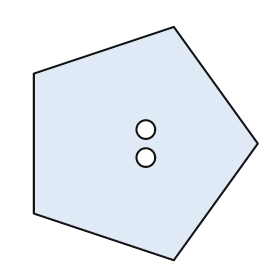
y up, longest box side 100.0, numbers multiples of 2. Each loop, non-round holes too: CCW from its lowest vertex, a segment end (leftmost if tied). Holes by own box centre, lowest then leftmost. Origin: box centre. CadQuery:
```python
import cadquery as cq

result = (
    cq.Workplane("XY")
    .moveTo(12.0, -50.0)
    .lineTo(48.0, 0.0)
    .lineTo(12.0, 50.0)
    .lineTo(-48.0, 30.0)
    .lineTo(-48.0, -30.0)
    .close()
    .moveTo(0.0, -6.0)
    .circle(4.0)
    .moveTo(0.0, 6.0)
    .circle(4.0)
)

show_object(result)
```